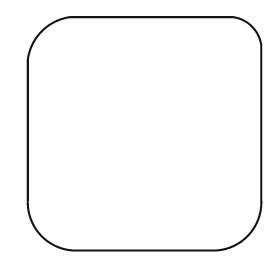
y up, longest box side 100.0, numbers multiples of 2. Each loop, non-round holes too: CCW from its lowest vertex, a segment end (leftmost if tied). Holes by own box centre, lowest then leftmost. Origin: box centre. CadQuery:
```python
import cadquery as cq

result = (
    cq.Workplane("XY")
    .moveTo(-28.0, -50.0)
    .lineTo(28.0, -50.0)
    .threePointArc((44.0, -44.0), (50.0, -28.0))
    .lineTo(50.0, 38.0)
    .threePointArc((46.0, 46.0), (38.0, 50.0))
    .lineTo(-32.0, 50.0)
    .threePointArc((-44.0, 44.0), (-50.0, 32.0))
    .lineTo(-50.0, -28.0)
    .threePointArc((-44.0, -44.0), (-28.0, -50.0))
    .close()
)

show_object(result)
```